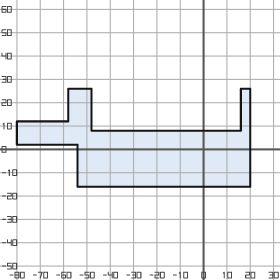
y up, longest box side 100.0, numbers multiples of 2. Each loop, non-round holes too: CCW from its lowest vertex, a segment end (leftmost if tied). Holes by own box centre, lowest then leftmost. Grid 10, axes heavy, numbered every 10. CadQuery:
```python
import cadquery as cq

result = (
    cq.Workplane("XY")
    .moveTo(-54.0, -16.0)
    .lineTo(20.0, -16.0)
    .lineTo(20.0, 26.0)
    .lineTo(16.0, 26.0)
    .lineTo(16.0, 8.0)
    .lineTo(-48.0, 8.0)
    .lineTo(-48.0, 26.0)
    .lineTo(-58.0, 26.0)
    .lineTo(-58.0, 12.0)
    .lineTo(-80.0, 12.0)
    .lineTo(-80.0, 2.0)
    .lineTo(-54.0, 2.0)
    .close()
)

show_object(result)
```